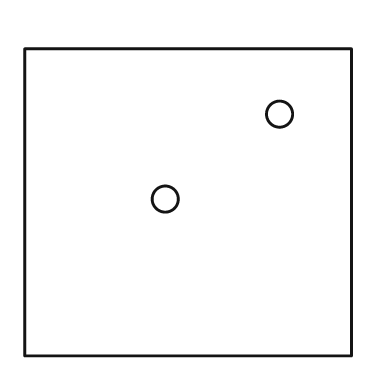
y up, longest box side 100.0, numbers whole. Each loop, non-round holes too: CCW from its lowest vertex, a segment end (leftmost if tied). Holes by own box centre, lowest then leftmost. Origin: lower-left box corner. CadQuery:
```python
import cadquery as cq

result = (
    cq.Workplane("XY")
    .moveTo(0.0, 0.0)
    .lineTo(100.0, 0.0)
    .lineTo(100.0, 94.0)
    .lineTo(0.0, 94.0)
    .close()
    .moveTo(43.0, 48.0)
    .circle(4.0)
    .moveTo(78.0, 74.0)
    .circle(4.0)
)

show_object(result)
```